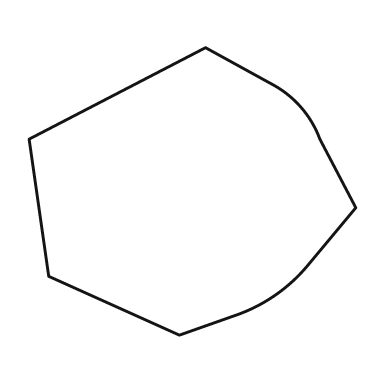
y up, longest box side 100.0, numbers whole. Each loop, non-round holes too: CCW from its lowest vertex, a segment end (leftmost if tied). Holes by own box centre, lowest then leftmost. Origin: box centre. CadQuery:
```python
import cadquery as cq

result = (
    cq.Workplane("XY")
    .moveTo(-4.0, -44.0)
    .lineTo(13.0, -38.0)
    .threePointArc((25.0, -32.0), (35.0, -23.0))
    .lineTo(50.0, -5.0)
    .lineTo(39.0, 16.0)
    .threePointArc((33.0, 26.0), (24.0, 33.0))
    .lineTo(4.0, 44.0)
    .lineTo(-50.0, 16.0)
    .lineTo(-44.0, -26.0)
    .close()
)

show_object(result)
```